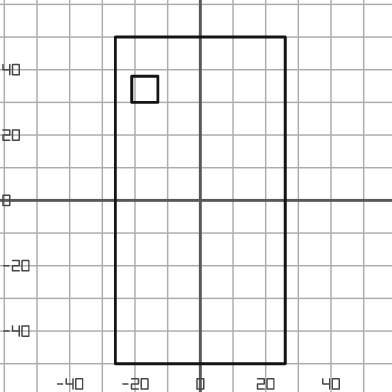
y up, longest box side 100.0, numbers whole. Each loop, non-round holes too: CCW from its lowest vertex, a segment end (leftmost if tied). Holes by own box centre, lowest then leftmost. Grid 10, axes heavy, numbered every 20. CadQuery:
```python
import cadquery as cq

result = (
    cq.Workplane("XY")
    .moveTo(-26.0, -50.0)
    .lineTo(26.0, -50.0)
    .lineTo(26.0, 50.0)
    .lineTo(-26.0, 50.0)
    .close()
    .moveTo(-21.0, 30.0)
    .lineTo(-13.0, 30.0)
    .lineTo(-13.0, 38.0)
    .lineTo(-21.0, 38.0)
    .close()
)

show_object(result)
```